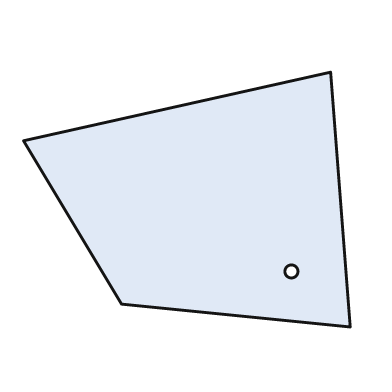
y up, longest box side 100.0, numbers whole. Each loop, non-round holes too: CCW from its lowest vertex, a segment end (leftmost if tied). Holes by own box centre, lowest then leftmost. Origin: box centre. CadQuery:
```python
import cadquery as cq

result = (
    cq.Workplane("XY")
    .moveTo(50.0, -39.0)
    .lineTo(44.0, 39.0)
    .lineTo(-50.0, 18.0)
    .lineTo(-20.0, -32.0)
    .close()
    .moveTo(32.0, -22.0)
    .circle(2.0)
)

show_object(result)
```